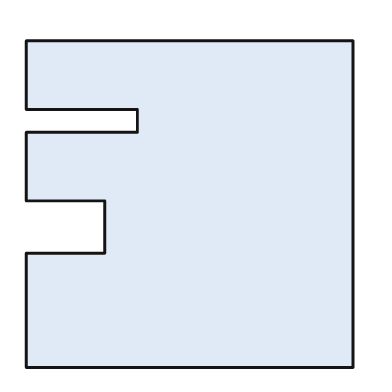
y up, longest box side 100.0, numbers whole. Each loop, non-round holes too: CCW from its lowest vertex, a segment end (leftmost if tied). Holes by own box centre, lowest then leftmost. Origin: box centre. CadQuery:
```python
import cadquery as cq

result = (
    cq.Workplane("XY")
    .moveTo(-50.0, -50.0)
    .lineTo(50.0, -50.0)
    .lineTo(50.0, 50.0)
    .lineTo(-50.0, 50.0)
    .lineTo(-50.0, 29.0)
    .lineTo(-16.0, 29.0)
    .lineTo(-16.0, 22.0)
    .lineTo(-50.0, 22.0)
    .lineTo(-50.0, 1.0)
    .lineTo(-26.0, 1.0)
    .lineTo(-26.0, -15.0)
    .lineTo(-50.0, -15.0)
    .close()
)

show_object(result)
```